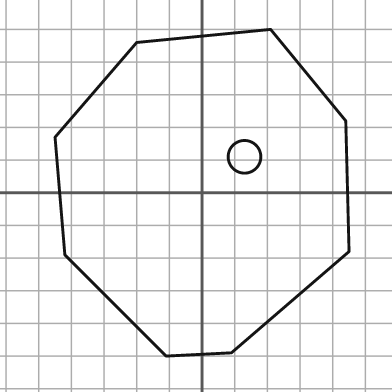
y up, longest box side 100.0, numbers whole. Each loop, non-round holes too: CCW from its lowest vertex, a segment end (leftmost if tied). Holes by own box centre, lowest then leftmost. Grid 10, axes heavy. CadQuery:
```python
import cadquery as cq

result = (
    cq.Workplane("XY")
    .moveTo(-11.0, -50.0)
    .lineTo(9.0, -49.0)
    .lineTo(45.0, -18.0)
    .lineTo(44.0, 22.0)
    .lineTo(21.0, 50.0)
    .lineTo(-20.0, 46.0)
    .lineTo(-45.0, 17.0)
    .lineTo(-42.0, -19.0)
    .close()
    .moveTo(13.0, 11.0)
    .circle(5.0)
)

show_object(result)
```